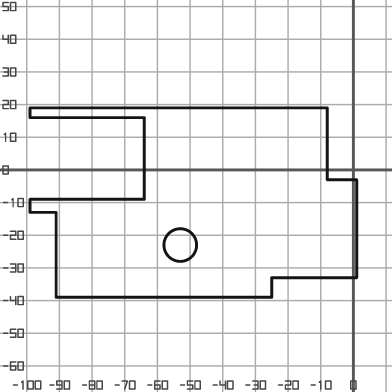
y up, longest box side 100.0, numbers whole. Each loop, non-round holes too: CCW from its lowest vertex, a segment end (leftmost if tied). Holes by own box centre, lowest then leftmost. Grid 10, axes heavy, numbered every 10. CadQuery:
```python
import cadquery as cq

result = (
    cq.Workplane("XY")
    .moveTo(-91.0, -39.0)
    .lineTo(-25.0, -39.0)
    .lineTo(-25.0, -33.0)
    .lineTo(1.0, -33.0)
    .lineTo(1.0, -3.0)
    .lineTo(-8.0, -3.0)
    .lineTo(-8.0, 19.0)
    .lineTo(-99.0, 19.0)
    .lineTo(-99.0, 16.0)
    .lineTo(-64.0, 16.0)
    .lineTo(-64.0, -9.0)
    .lineTo(-99.0, -9.0)
    .lineTo(-99.0, -13.0)
    .lineTo(-91.0, -13.0)
    .close()
    .moveTo(-53.0, -23.0)
    .circle(5.0)
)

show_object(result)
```